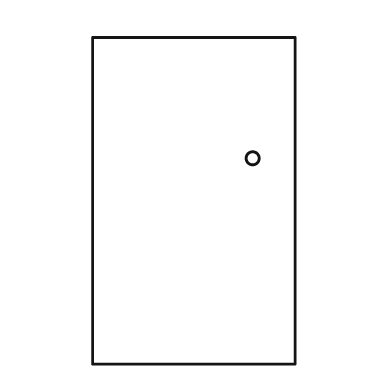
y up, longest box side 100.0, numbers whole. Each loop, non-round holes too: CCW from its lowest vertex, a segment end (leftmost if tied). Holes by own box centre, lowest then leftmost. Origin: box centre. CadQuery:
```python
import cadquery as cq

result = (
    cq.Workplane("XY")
    .moveTo(-31.0, -50.0)
    .lineTo(31.0, -50.0)
    .lineTo(31.0, 50.0)
    .lineTo(-31.0, 50.0)
    .close()
    .moveTo(18.0, 13.0)
    .circle(2.0)
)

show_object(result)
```